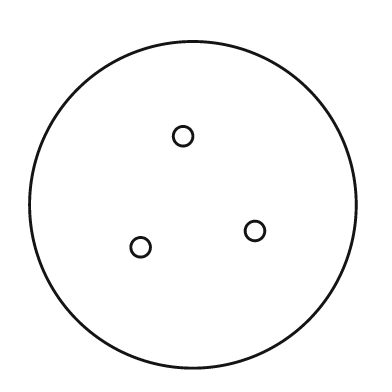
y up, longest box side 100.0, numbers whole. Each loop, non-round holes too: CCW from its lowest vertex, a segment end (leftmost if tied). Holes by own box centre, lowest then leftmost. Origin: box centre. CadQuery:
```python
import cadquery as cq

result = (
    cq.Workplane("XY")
    .moveTo(0.0, 0.0)
    .circle(50.0)
    .moveTo(-16.0, -13.0)
    .circle(3.0)
    .moveTo(19.0, -8.0)
    .circle(3.0)
    .moveTo(-3.0, 21.0)
    .circle(3.0)
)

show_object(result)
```